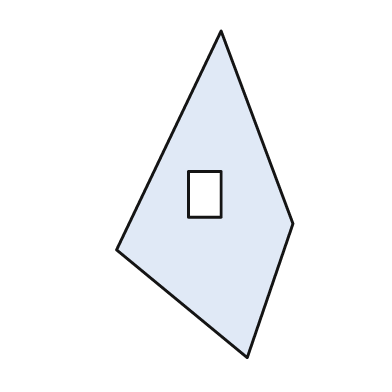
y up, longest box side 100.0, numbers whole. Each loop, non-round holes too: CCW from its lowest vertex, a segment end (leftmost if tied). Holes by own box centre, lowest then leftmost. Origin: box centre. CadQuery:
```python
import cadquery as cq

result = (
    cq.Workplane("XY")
    .moveTo(13.0, -50.0)
    .lineTo(27.0, -9.0)
    .lineTo(5.0, 50.0)
    .lineTo(-27.0, -17.0)
    .close()
    .moveTo(-5.0, -7.0)
    .lineTo(5.0, -7.0)
    .lineTo(5.0, 7.0)
    .lineTo(-5.0, 7.0)
    .close()
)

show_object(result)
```